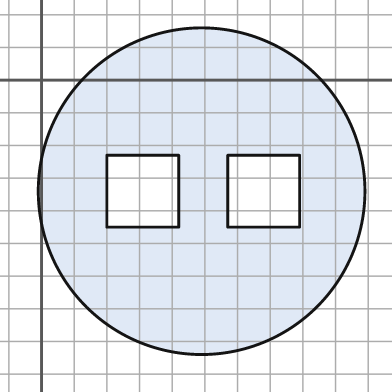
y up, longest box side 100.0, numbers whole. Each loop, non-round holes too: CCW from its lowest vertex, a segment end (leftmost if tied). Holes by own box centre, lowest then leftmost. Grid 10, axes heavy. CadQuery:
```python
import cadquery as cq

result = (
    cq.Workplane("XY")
    .moveTo(49.0, -34.0)
    .circle(50.0)
    .moveTo(20.0, -45.0)
    .lineTo(42.0, -45.0)
    .lineTo(42.0, -23.0)
    .lineTo(20.0, -23.0)
    .close()
    .moveTo(57.0, -45.0)
    .lineTo(79.0, -45.0)
    .lineTo(79.0, -23.0)
    .lineTo(57.0, -23.0)
    .close()
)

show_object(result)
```